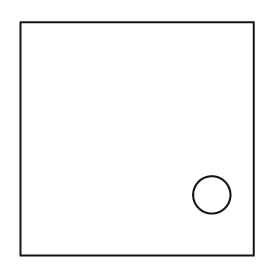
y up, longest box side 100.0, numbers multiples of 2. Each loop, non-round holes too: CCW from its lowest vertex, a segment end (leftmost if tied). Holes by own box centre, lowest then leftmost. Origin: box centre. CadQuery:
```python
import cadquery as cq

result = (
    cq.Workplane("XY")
    .moveTo(-50.0, -50.0)
    .lineTo(50.0, -50.0)
    .lineTo(50.0, 50.0)
    .lineTo(-50.0, 50.0)
    .close()
    .moveTo(32.0, -24.0)
    .circle(8.0)
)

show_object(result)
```